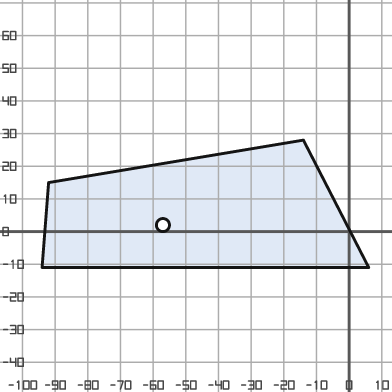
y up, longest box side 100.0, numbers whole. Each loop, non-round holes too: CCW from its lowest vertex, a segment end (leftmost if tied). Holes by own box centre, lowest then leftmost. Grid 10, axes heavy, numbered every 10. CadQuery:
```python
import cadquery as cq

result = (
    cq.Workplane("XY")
    .moveTo(-94.0, -11.0)
    .lineTo(6.0, -11.0)
    .lineTo(-14.0, 28.0)
    .lineTo(-92.0, 15.0)
    .close()
    .moveTo(-57.0, 2.0)
    .circle(2.0)
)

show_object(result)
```